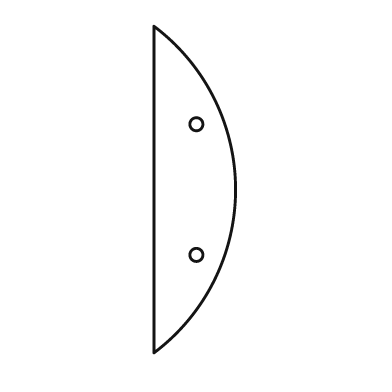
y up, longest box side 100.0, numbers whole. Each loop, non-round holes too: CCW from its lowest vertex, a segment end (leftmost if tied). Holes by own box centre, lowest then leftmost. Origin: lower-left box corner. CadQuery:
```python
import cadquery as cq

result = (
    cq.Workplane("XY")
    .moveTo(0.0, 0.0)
    .threePointArc((25.0, 50.0), (0.0, 100.0))
    .close()
    .moveTo(13.0, 30.0)
    .circle(2.0)
    .moveTo(13.0, 70.0)
    .circle(2.0)
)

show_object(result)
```